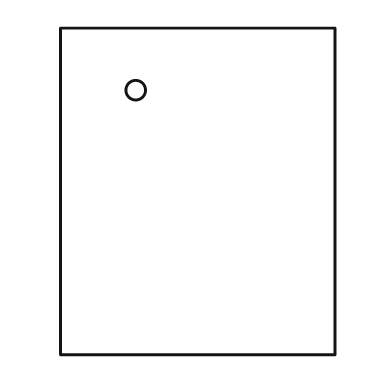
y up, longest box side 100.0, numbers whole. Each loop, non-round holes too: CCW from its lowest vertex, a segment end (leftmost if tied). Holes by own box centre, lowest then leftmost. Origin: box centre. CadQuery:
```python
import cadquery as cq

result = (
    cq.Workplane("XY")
    .moveTo(-42.0, -50.0)
    .lineTo(42.0, -50.0)
    .lineTo(42.0, 50.0)
    .lineTo(-42.0, 50.0)
    .close()
    .moveTo(-19.0, 31.0)
    .circle(3.0)
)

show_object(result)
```